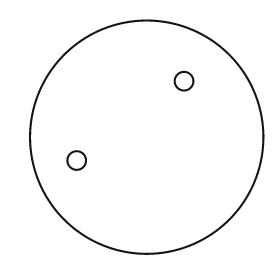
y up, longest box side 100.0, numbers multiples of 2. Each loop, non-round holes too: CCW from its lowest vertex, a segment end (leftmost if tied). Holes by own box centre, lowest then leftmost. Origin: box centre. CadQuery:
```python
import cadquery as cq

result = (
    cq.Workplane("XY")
    .moveTo(0.0, 0.0)
    .circle(50.0)
    .moveTo(-30.0, -10.0)
    .circle(4.0)
    .moveTo(16.0, 24.0)
    .circle(4.0)
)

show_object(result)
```